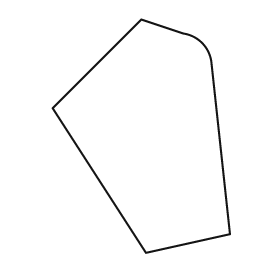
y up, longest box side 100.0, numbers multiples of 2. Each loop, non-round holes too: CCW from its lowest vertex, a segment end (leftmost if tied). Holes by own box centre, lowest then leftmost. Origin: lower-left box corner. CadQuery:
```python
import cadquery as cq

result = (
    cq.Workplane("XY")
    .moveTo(40.0, 0.0)
    .lineTo(76.0, 8.0)
    .lineTo(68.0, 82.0)
    .threePointArc((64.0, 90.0), (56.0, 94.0))
    .lineTo(38.0, 100.0)
    .lineTo(0.0, 62.0)
    .close()
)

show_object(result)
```